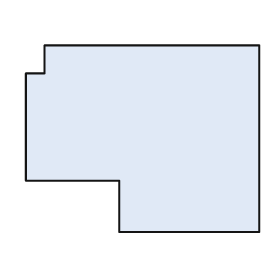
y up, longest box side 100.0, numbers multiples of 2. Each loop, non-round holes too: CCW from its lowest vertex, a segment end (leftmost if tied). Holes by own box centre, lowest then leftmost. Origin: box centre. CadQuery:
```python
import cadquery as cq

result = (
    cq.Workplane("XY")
    .moveTo(-10.0, -40.0)
    .lineTo(50.0, -40.0)
    .lineTo(50.0, 40.0)
    .lineTo(-42.0, 40.0)
    .lineTo(-42.0, 28.0)
    .lineTo(-50.0, 28.0)
    .lineTo(-50.0, -18.0)
    .lineTo(-10.0, -18.0)
    .close()
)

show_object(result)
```